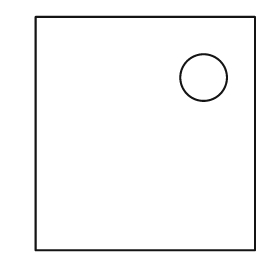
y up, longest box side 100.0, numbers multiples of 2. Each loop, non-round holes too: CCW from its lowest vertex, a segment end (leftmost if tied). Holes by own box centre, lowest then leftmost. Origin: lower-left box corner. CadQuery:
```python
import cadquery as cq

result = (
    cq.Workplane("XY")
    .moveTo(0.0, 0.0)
    .lineTo(94.0, 0.0)
    .lineTo(94.0, 100.0)
    .lineTo(0.0, 100.0)
    .close()
    .moveTo(72.0, 74.0)
    .circle(10.0)
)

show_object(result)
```